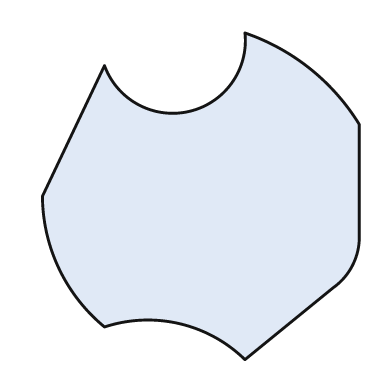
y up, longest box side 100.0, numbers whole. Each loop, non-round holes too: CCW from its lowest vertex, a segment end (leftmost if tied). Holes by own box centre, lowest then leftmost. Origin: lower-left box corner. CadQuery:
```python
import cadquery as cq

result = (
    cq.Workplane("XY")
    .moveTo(62.0, 0.0)
    .lineTo(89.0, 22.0)
    .threePointArc((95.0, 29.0), (97.0, 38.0))
    .lineTo(97.0, 72.0)
    .threePointArc((82.0, 89.0), (62.0, 100.0))
    .threePointArc((45.0, 76.0), (19.0, 90.0))
    .lineTo(0.0, 50.0)
    .threePointArc((5.0, 28.0), (19.0, 10.0))
    .threePointArc((42.0, 11.0), (62.0, 0.0))
    .close()
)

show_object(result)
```